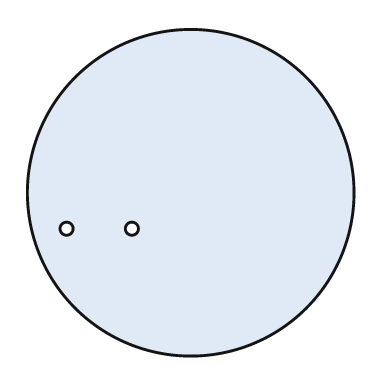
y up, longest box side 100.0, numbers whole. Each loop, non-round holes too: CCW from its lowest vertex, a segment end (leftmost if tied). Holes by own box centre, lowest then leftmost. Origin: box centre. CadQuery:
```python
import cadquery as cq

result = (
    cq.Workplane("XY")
    .moveTo(0.0, 0.0)
    .circle(50.0)
    .moveTo(-38.0, -11.0)
    .circle(2.0)
    .moveTo(-18.0, -11.0)
    .circle(2.0)
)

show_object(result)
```